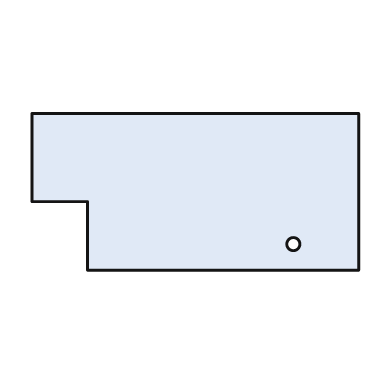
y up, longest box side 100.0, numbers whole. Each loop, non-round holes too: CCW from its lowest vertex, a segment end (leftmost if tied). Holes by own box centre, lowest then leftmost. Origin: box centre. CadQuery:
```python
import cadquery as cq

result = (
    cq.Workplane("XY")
    .moveTo(-33.0, -24.0)
    .lineTo(50.0, -24.0)
    .lineTo(50.0, 24.0)
    .lineTo(-50.0, 24.0)
    .lineTo(-50.0, -3.0)
    .lineTo(-33.0, -3.0)
    .close()
    .moveTo(30.0, -16.0)
    .circle(2.0)
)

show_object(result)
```